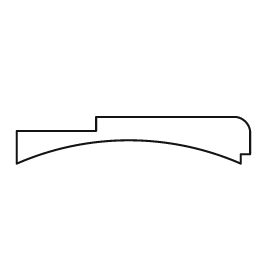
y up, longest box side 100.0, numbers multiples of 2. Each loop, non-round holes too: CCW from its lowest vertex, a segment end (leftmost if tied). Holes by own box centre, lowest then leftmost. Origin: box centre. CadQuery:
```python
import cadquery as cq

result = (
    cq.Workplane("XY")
    .moveTo(-50.0, -10.0)
    .threePointArc((-2.0, 0.0), (46.0, -10.0))
    .lineTo(46.0, -6.0)
    .lineTo(50.0, -6.0)
    .lineTo(50.0, 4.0)
    .threePointArc((48.0, 8.0), (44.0, 10.0))
    .lineTo(-16.0, 10.0)
    .lineTo(-16.0, 4.0)
    .lineTo(-50.0, 4.0)
    .close()
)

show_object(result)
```